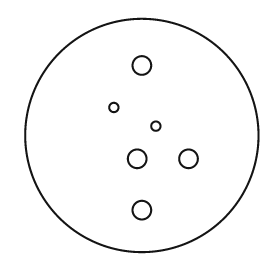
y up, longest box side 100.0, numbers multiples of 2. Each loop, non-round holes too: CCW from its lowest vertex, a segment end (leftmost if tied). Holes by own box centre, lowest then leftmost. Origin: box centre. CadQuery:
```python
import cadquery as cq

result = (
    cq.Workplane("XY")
    .moveTo(0.0, 0.0)
    .circle(50.0)
    .moveTo(0.0, -32.0)
    .circle(4.0)
    .moveTo(-2.0, -10.0)
    .circle(4.0)
    .moveTo(20.0, -10.0)
    .circle(4.0)
    .moveTo(6.0, 4.0)
    .circle(2.0)
    .moveTo(-12.0, 12.0)
    .circle(2.0)
    .moveTo(0.0, 30.0)
    .circle(4.0)
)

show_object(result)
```